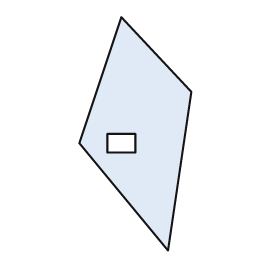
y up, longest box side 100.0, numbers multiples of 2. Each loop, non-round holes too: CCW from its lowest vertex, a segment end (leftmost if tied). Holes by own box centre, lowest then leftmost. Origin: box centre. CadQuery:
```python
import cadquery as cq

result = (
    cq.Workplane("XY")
    .moveTo(14.0, -50.0)
    .lineTo(24.0, 18.0)
    .lineTo(-6.0, 50.0)
    .lineTo(-24.0, -4.0)
    .close()
    .moveTo(-12.0, -8.0)
    .lineTo(0.0, -8.0)
    .lineTo(0.0, 0.0)
    .lineTo(-12.0, 0.0)
    .close()
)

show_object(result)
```